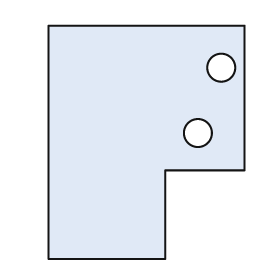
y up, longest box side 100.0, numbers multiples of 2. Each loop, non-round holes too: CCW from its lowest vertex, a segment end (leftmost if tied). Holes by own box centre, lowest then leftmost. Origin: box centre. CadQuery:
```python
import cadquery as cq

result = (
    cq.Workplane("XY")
    .moveTo(-42.0, -50.0)
    .lineTo(8.0, -50.0)
    .lineTo(8.0, -12.0)
    .lineTo(42.0, -12.0)
    .lineTo(42.0, 50.0)
    .lineTo(-42.0, 50.0)
    .close()
    .moveTo(22.0, 4.0)
    .circle(6.0)
    .moveTo(32.0, 32.0)
    .circle(6.0)
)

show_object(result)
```